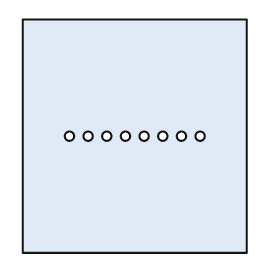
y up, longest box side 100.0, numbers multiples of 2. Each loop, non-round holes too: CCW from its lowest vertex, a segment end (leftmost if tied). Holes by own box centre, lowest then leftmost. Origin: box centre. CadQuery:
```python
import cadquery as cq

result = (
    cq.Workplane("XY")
    .moveTo(-48.0, -50.0)
    .lineTo(48.0, -50.0)
    .lineTo(48.0, 50.0)
    .lineTo(-48.0, 50.0)
    .close()
    .moveTo(-28.0, 0.0)
    .circle(2.0)
    .moveTo(-20.0, 0.0)
    .circle(2.0)
    .moveTo(-12.0, 0.0)
    .circle(2.0)
    .moveTo(-4.0, 0.0)
    .circle(2.0)
    .moveTo(4.0, 0.0)
    .circle(2.0)
    .moveTo(12.0, 0.0)
    .circle(2.0)
    .moveTo(20.0, 0.0)
    .circle(2.0)
    .moveTo(28.0, 0.0)
    .circle(2.0)
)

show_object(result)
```